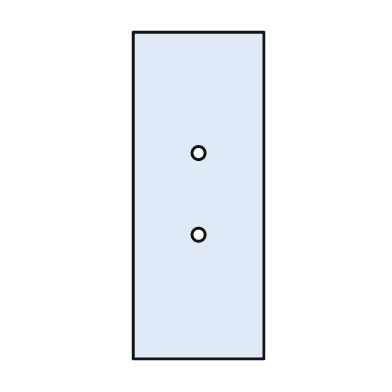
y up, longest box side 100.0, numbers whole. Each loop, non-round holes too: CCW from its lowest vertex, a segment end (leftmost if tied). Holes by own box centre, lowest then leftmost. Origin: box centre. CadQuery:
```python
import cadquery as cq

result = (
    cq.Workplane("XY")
    .moveTo(-20.0, -50.0)
    .lineTo(20.0, -50.0)
    .lineTo(20.0, 50.0)
    .lineTo(-20.0, 50.0)
    .close()
    .moveTo(0.0, -12.0)
    .circle(2.0)
    .moveTo(0.0, 13.0)
    .circle(2.0)
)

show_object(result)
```